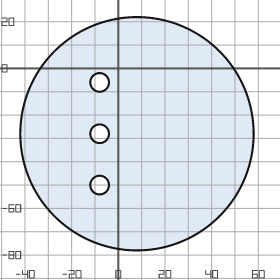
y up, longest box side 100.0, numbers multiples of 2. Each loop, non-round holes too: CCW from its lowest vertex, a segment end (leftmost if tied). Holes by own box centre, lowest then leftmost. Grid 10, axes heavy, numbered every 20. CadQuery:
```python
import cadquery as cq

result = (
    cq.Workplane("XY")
    .moveTo(8.0, -28.0)
    .circle(50.0)
    .moveTo(-8.0, -50.0)
    .circle(4.0)
    .moveTo(-8.0, -28.0)
    .circle(4.0)
    .moveTo(-8.0, -6.0)
    .circle(4.0)
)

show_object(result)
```